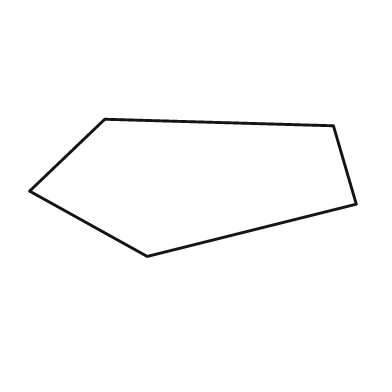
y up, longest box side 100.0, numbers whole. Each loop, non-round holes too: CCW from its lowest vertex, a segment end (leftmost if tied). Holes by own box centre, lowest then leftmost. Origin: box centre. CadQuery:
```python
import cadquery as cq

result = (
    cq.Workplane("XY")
    .moveTo(-14.0, -21.0)
    .lineTo(50.0, -5.0)
    .lineTo(43.0, 19.0)
    .lineTo(-27.0, 21.0)
    .lineTo(-50.0, -1.0)
    .close()
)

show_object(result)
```